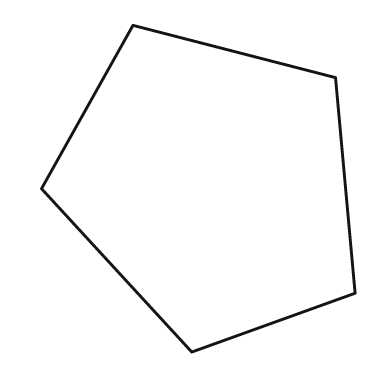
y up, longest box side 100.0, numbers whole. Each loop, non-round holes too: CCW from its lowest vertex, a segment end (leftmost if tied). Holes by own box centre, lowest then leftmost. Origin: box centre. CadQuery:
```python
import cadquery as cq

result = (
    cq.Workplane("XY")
    .moveTo(-2.0, -50.0)
    .lineTo(48.0, -32.0)
    .lineTo(42.0, 34.0)
    .lineTo(-20.0, 50.0)
    .lineTo(-48.0, 0.0)
    .close()
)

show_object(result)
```